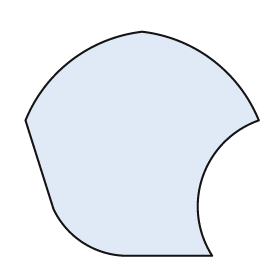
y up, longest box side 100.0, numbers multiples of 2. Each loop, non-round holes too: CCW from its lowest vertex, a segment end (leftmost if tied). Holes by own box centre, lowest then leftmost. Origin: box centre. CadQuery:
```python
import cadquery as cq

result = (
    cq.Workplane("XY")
    .moveTo(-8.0, -48.0)
    .lineTo(30.0, -48.0)
    .threePointArc((26.0, -14.0), (50.0, 10.0))
    .threePointArc((30.0, 36.0), (0.0, 48.0))
    .threePointArc((-30.0, 36.0), (-50.0, 10.0))
    .lineTo(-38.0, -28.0)
    .threePointArc((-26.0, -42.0), (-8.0, -48.0))
    .close()
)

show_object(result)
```